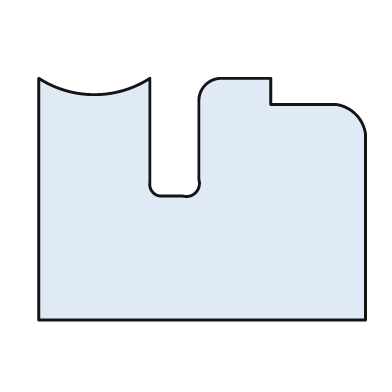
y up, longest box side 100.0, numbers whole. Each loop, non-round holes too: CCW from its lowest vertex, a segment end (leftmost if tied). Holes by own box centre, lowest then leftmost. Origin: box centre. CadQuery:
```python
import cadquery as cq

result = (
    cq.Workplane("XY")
    .moveTo(-50.0, -37.0)
    .lineTo(50.0, -37.0)
    .lineTo(50.0, 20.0)
    .threePointArc((47.0, 26.0), (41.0, 29.0))
    .lineTo(21.0, 29.0)
    .lineTo(21.0, 37.0)
    .lineTo(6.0, 37.0)
    .threePointArc((1.0, 35.0), (-1.0, 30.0))
    .lineTo(-1.0, 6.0)
    .threePointArc((-2.0, 2.0), (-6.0, 1.0))
    .lineTo(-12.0, 1.0)
    .threePointArc((-15.0, 2.0), (-16.0, 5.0))
    .lineTo(-16.0, 37.0)
    .threePointArc((-33.0, 32.0), (-50.0, 37.0))
    .close()
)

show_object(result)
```